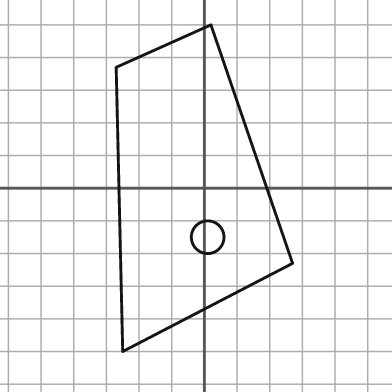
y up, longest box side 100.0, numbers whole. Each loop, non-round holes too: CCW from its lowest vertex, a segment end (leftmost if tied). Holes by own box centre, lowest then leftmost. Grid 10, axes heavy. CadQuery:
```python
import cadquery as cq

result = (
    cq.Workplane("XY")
    .moveTo(-25.0, -50.0)
    .lineTo(27.0, -23.0)
    .lineTo(2.0, 50.0)
    .lineTo(-27.0, 37.0)
    .close()
    .moveTo(1.0, -15.0)
    .circle(5.0)
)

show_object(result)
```